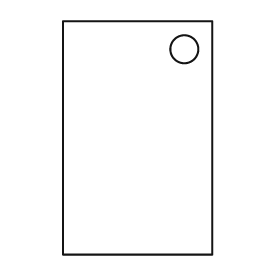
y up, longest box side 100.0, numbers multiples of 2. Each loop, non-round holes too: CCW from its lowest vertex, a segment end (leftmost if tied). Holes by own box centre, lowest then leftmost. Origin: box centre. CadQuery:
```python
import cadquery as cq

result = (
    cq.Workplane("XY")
    .moveTo(-32.0, -50.0)
    .lineTo(32.0, -50.0)
    .lineTo(32.0, 50.0)
    .lineTo(-32.0, 50.0)
    .close()
    .moveTo(20.0, 38.0)
    .circle(6.0)
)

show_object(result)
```